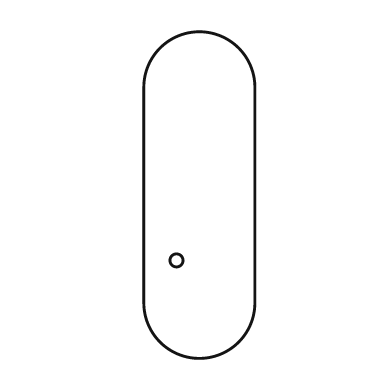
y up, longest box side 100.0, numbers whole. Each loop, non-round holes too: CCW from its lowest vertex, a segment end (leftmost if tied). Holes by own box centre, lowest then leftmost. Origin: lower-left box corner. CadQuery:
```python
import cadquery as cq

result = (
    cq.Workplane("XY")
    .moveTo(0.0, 17.0)
    .threePointArc((17.0, 0.0), (34.0, 17.0))
    .lineTo(34.0, 83.0)
    .threePointArc((17.0, 100.0), (0.0, 83.0))
    .close()
    .moveTo(10.0, 30.0)
    .circle(2.0)
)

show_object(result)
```